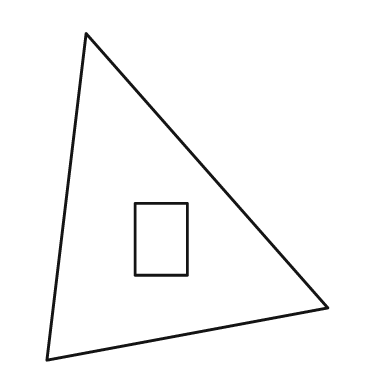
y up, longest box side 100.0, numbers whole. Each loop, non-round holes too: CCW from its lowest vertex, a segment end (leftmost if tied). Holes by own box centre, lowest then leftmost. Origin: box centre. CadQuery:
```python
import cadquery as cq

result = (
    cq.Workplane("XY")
    .moveTo(-43.0, -50.0)
    .lineTo(43.0, -34.0)
    .lineTo(-31.0, 50.0)
    .close()
    .moveTo(-16.0, -24.0)
    .lineTo(0.0, -24.0)
    .lineTo(0.0, -2.0)
    .lineTo(-16.0, -2.0)
    .close()
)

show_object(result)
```